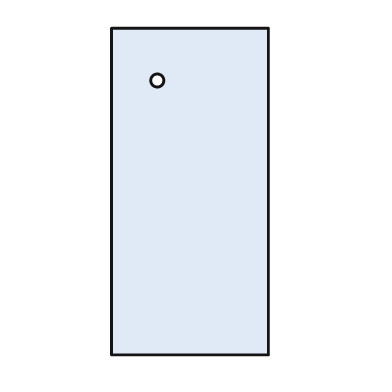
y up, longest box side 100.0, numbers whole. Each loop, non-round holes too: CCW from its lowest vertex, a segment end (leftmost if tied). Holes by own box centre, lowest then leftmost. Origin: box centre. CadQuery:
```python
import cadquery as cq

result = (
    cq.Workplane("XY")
    .moveTo(-24.0, -50.0)
    .lineTo(24.0, -50.0)
    .lineTo(24.0, 50.0)
    .lineTo(-24.0, 50.0)
    .close()
    .moveTo(-10.0, 34.0)
    .circle(2.0)
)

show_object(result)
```